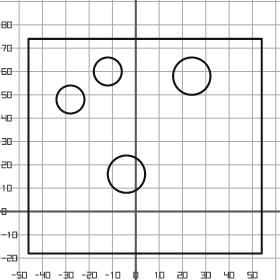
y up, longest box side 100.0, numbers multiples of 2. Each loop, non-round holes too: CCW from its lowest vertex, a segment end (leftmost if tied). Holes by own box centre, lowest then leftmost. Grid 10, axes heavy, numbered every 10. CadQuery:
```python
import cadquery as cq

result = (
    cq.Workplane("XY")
    .moveTo(-46.0, -18.0)
    .lineTo(54.0, -18.0)
    .lineTo(54.0, 74.0)
    .lineTo(-46.0, 74.0)
    .close()
    .moveTo(-4.0, 16.0)
    .circle(8.0)
    .moveTo(-28.0, 48.0)
    .circle(6.0)
    .moveTo(24.0, 58.0)
    .circle(8.0)
    .moveTo(-12.0, 60.0)
    .circle(6.0)
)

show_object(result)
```